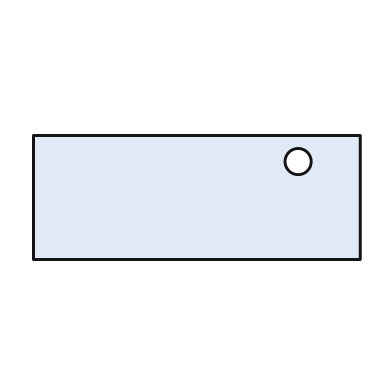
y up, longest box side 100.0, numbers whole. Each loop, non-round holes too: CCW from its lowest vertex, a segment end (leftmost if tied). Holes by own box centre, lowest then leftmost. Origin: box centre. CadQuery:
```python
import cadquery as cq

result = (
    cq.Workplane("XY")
    .moveTo(-50.0, -19.0)
    .lineTo(50.0, -19.0)
    .lineTo(50.0, 19.0)
    .lineTo(-50.0, 19.0)
    .close()
    .moveTo(31.0, 11.0)
    .circle(4.0)
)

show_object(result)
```